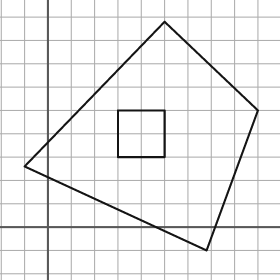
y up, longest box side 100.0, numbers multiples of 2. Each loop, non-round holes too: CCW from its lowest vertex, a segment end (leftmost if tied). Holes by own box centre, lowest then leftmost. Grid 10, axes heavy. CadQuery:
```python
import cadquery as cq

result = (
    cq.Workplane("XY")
    .moveTo(68.0, -10.0)
    .lineTo(90.0, 50.0)
    .lineTo(50.0, 88.0)
    .lineTo(-10.0, 26.0)
    .close()
    .moveTo(30.0, 30.0)
    .lineTo(50.0, 30.0)
    .lineTo(50.0, 50.0)
    .lineTo(30.0, 50.0)
    .close()
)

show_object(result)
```